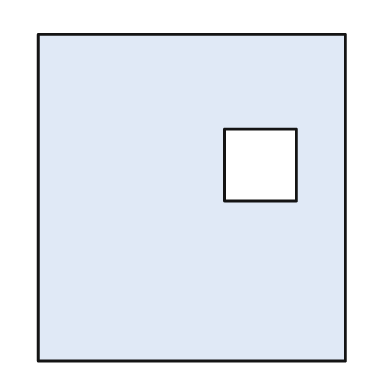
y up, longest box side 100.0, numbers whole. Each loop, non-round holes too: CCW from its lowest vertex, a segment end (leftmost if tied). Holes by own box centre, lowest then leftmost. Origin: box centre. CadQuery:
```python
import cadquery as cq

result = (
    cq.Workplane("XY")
    .moveTo(-47.0, -50.0)
    .lineTo(47.0, -50.0)
    .lineTo(47.0, 50.0)
    .lineTo(-47.0, 50.0)
    .close()
    .moveTo(10.0, -1.0)
    .lineTo(32.0, -1.0)
    .lineTo(32.0, 21.0)
    .lineTo(10.0, 21.0)
    .close()
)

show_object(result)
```